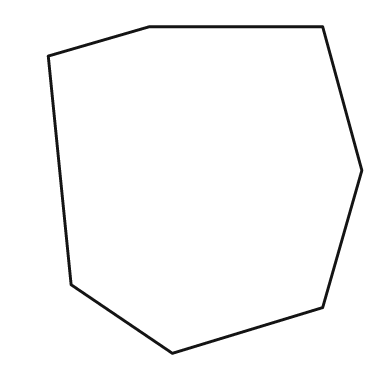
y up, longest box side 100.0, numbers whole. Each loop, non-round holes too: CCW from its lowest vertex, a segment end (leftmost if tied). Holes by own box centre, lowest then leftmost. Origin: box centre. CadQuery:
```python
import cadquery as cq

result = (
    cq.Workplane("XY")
    .moveTo(-10.0, -50.0)
    .lineTo(36.0, -36.0)
    .lineTo(48.0, 6.0)
    .lineTo(36.0, 50.0)
    .lineTo(-17.0, 50.0)
    .lineTo(-48.0, 41.0)
    .lineTo(-41.0, -29.0)
    .close()
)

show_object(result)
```